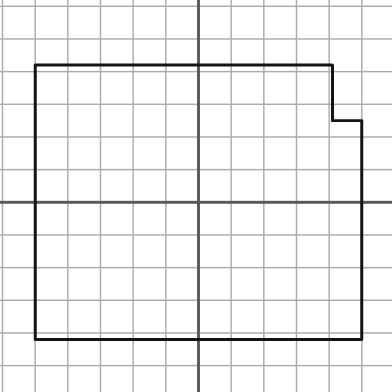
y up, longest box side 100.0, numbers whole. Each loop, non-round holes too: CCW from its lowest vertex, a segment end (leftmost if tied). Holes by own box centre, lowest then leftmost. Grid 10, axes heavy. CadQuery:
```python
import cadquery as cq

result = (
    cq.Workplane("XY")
    .moveTo(-50.0, -42.0)
    .lineTo(50.0, -42.0)
    .lineTo(50.0, 25.0)
    .lineTo(41.0, 25.0)
    .lineTo(41.0, 42.0)
    .lineTo(-50.0, 42.0)
    .close()
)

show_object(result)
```